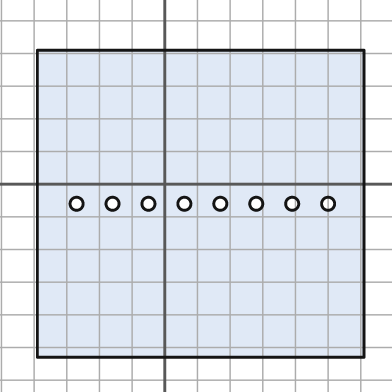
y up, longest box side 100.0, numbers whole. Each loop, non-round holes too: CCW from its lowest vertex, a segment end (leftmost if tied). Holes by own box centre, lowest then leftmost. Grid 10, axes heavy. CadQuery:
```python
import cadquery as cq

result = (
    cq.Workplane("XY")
    .moveTo(-39.0, -53.0)
    .lineTo(61.0, -53.0)
    .lineTo(61.0, 41.0)
    .lineTo(-39.0, 41.0)
    .close()
    .moveTo(-27.0, -6.0)
    .circle(2.0)
    .moveTo(-16.0, -6.0)
    .circle(2.0)
    .moveTo(-5.0, -6.0)
    .circle(2.0)
    .moveTo(6.0, -6.0)
    .circle(2.0)
    .moveTo(17.0, -6.0)
    .circle(2.0)
    .moveTo(28.0, -6.0)
    .circle(2.0)
    .moveTo(39.0, -6.0)
    .circle(2.0)
    .moveTo(50.0, -6.0)
    .circle(2.0)
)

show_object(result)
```